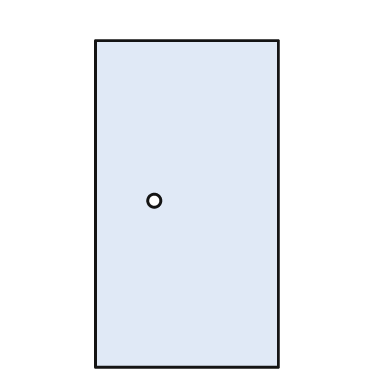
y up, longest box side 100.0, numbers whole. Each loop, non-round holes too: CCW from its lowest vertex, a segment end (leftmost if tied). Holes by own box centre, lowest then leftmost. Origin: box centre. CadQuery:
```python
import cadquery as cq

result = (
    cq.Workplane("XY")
    .moveTo(-28.0, -50.0)
    .lineTo(28.0, -50.0)
    .lineTo(28.0, 50.0)
    .lineTo(-28.0, 50.0)
    .close()
    .moveTo(-10.0, 1.0)
    .circle(2.0)
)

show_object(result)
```